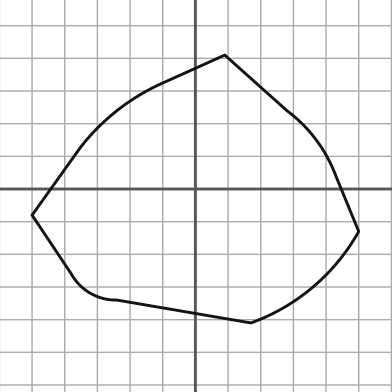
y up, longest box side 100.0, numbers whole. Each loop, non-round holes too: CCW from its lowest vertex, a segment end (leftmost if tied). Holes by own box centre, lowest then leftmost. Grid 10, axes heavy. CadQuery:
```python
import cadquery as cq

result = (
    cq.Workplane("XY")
    .moveTo(17.0, -41.0)
    .threePointArc((36.0, -30.0), (50.0, -13.0))
    .lineTo(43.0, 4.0)
    .threePointArc((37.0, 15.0), (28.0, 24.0))
    .lineTo(9.0, 41.0)
    .lineTo(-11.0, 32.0)
    .threePointArc((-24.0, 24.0), (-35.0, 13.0))
    .lineTo(-50.0, -8.0)
    .lineTo(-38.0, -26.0)
    .threePointArc((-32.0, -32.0), (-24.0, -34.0))
    .close()
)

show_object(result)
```